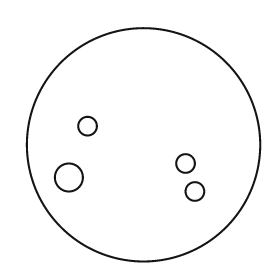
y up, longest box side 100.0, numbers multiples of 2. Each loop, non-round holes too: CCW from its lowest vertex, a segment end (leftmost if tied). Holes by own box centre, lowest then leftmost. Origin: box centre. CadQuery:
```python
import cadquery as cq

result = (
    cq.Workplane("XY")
    .moveTo(0.0, 0.0)
    .circle(50.0)
    .moveTo(22.0, -20.0)
    .circle(4.0)
    .moveTo(-32.0, -14.0)
    .circle(6.0)
    .moveTo(18.0, -8.0)
    .circle(4.0)
    .moveTo(-24.0, 8.0)
    .circle(4.0)
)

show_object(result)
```